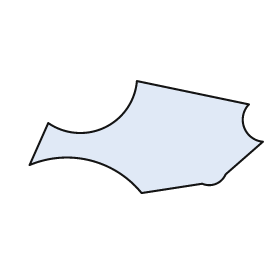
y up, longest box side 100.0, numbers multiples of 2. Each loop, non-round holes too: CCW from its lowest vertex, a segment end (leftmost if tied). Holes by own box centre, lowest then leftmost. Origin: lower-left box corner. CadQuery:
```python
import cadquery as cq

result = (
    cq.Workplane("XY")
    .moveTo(48.0, 0.0)
    .lineTo(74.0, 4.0)
    .threePointArc((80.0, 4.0), (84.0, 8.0))
    .lineTo(100.0, 22.0)
    .threePointArc((92.0, 28.0), (94.0, 38.0))
    .lineTo(46.0, 48.0)
    .threePointArc((32.0, 28.0), (8.0, 30.0))
    .lineTo(0.0, 12.0)
    .threePointArc((26.0, 14.0), (48.0, 0.0))
    .close()
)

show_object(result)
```